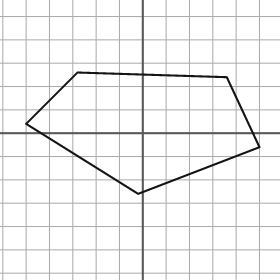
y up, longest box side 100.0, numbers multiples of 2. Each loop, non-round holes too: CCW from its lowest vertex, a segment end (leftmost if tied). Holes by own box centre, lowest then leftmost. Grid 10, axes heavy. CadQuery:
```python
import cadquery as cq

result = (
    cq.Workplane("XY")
    .moveTo(-2.0, -26.0)
    .lineTo(50.0, -6.0)
    .lineTo(36.0, 24.0)
    .lineTo(-28.0, 26.0)
    .lineTo(-50.0, 4.0)
    .close()
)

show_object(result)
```